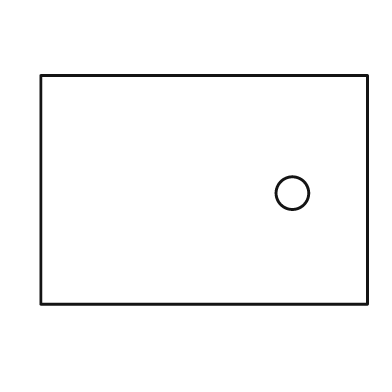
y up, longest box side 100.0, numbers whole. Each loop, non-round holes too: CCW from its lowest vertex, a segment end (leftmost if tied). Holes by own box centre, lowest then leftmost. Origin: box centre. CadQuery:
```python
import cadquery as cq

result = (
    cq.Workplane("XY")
    .moveTo(-50.0, -35.0)
    .lineTo(50.0, -35.0)
    .lineTo(50.0, 35.0)
    .lineTo(-50.0, 35.0)
    .close()
    .moveTo(27.0, -1.0)
    .circle(5.0)
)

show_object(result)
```